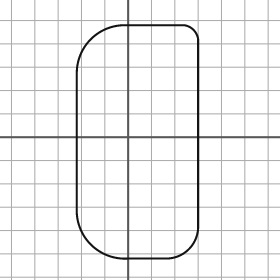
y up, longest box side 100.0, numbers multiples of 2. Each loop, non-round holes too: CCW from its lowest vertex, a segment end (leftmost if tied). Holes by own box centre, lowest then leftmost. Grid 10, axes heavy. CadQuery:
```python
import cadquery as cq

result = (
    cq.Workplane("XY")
    .moveTo(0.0, -52.0)
    .lineTo(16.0, -52.0)
    .threePointArc((26.0, -48.0), (30.0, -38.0))
    .lineTo(30.0, 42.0)
    .threePointArc((28.0, 46.0), (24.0, 48.0))
    .lineTo(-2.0, 48.0)
    .threePointArc((-16.0, 42.0), (-22.0, 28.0))
    .lineTo(-22.0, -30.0)
    .threePointArc((-16.0, -46.0), (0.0, -52.0))
    .close()
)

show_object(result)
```